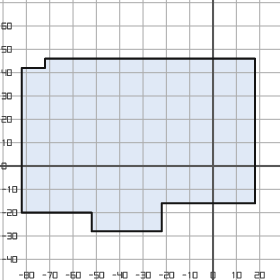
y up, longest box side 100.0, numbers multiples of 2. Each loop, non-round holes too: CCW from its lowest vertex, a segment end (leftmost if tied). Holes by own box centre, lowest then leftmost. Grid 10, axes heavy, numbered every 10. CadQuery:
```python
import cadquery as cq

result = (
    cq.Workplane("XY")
    .moveTo(-52.0, -28.0)
    .lineTo(-22.0, -28.0)
    .lineTo(-22.0, -16.0)
    .lineTo(18.0, -16.0)
    .lineTo(18.0, 46.0)
    .lineTo(-72.0, 46.0)
    .lineTo(-72.0, 42.0)
    .lineTo(-82.0, 42.0)
    .lineTo(-82.0, -20.0)
    .lineTo(-52.0, -20.0)
    .close()
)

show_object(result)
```